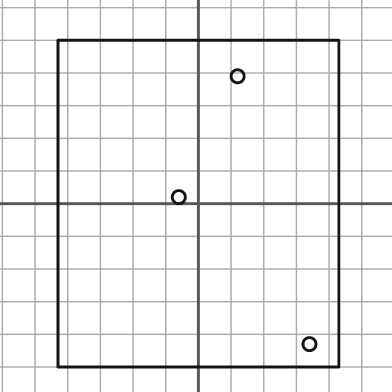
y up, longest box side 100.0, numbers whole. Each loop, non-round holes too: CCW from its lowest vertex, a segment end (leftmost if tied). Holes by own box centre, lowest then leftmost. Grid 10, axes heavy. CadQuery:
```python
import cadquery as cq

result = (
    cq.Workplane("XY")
    .moveTo(-43.0, -50.0)
    .lineTo(43.0, -50.0)
    .lineTo(43.0, 50.0)
    .lineTo(-43.0, 50.0)
    .close()
    .moveTo(34.0, -43.0)
    .circle(2.0)
    .moveTo(-6.0, 2.0)
    .circle(2.0)
    .moveTo(12.0, 39.0)
    .circle(2.0)
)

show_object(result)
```